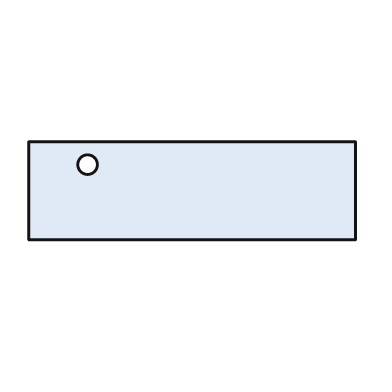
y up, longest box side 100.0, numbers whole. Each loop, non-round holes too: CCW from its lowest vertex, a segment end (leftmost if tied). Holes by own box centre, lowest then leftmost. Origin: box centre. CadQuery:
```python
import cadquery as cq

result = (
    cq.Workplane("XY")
    .moveTo(-50.0, -15.0)
    .lineTo(50.0, -15.0)
    .lineTo(50.0, 15.0)
    .lineTo(-50.0, 15.0)
    .close()
    .moveTo(-32.0, 8.0)
    .circle(3.0)
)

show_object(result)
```